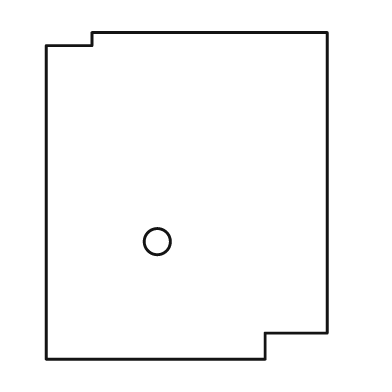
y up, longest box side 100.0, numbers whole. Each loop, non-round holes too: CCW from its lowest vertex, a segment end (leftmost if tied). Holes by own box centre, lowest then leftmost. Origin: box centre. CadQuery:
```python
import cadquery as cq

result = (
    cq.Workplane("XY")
    .moveTo(-43.0, -50.0)
    .lineTo(24.0, -50.0)
    .lineTo(24.0, -42.0)
    .lineTo(43.0, -42.0)
    .lineTo(43.0, 50.0)
    .lineTo(-29.0, 50.0)
    .lineTo(-29.0, 46.0)
    .lineTo(-43.0, 46.0)
    .close()
    .moveTo(-9.0, -14.0)
    .circle(4.0)
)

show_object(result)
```